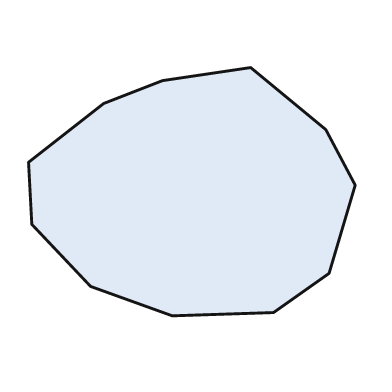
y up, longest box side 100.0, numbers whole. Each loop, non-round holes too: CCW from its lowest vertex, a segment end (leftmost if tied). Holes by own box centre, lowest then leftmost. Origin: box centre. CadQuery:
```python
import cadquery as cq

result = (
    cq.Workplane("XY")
    .moveTo(-6.0, -38.0)
    .lineTo(25.0, -37.0)
    .lineTo(42.0, -25.0)
    .lineTo(50.0, 2.0)
    .lineTo(41.0, 19.0)
    .lineTo(18.0, 38.0)
    .lineTo(-9.0, 34.0)
    .lineTo(-27.0, 27.0)
    .lineTo(-50.0, 9.0)
    .lineTo(-49.0, -10.0)
    .lineTo(-31.0, -29.0)
    .close()
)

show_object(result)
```